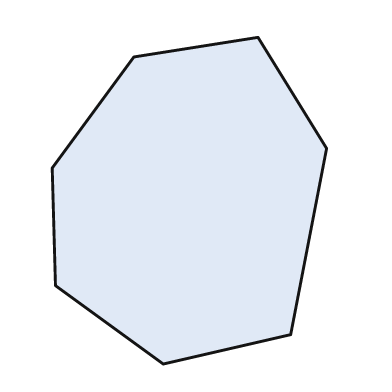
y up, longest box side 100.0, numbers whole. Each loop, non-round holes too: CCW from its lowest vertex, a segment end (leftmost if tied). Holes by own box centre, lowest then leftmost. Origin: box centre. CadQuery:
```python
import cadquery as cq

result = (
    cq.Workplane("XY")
    .moveTo(-8.0, -50.0)
    .lineTo(31.0, -41.0)
    .lineTo(42.0, 16.0)
    .lineTo(21.0, 50.0)
    .lineTo(-17.0, 44.0)
    .lineTo(-42.0, 10.0)
    .lineTo(-41.0, -26.0)
    .close()
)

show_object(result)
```